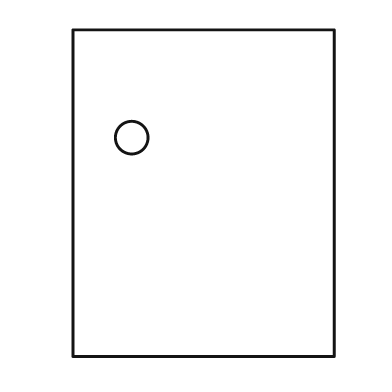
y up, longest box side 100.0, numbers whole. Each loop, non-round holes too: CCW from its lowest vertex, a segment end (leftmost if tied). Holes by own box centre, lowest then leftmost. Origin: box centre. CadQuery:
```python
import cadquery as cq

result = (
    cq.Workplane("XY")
    .moveTo(-40.0, -50.0)
    .lineTo(40.0, -50.0)
    .lineTo(40.0, 50.0)
    .lineTo(-40.0, 50.0)
    .close()
    .moveTo(-22.0, 17.0)
    .circle(5.0)
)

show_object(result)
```